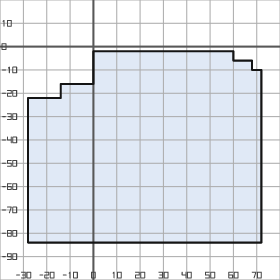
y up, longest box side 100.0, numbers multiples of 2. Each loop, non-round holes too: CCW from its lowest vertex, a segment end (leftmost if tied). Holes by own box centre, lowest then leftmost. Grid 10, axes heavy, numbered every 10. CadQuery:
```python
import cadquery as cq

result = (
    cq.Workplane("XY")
    .moveTo(-28.0, -84.0)
    .lineTo(72.0, -84.0)
    .lineTo(72.0, -10.0)
    .lineTo(68.0, -10.0)
    .lineTo(68.0, -6.0)
    .lineTo(60.0, -6.0)
    .lineTo(60.0, -2.0)
    .lineTo(0.0, -2.0)
    .lineTo(0.0, -16.0)
    .lineTo(-14.0, -16.0)
    .lineTo(-14.0, -22.0)
    .lineTo(-28.0, -22.0)
    .close()
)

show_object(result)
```